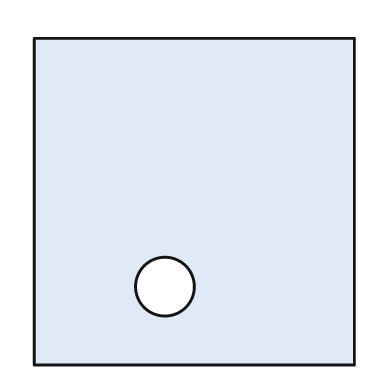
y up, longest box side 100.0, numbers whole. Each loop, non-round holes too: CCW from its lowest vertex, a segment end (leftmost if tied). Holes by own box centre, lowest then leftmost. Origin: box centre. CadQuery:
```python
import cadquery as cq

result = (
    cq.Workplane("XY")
    .moveTo(-49.0, -50.0)
    .lineTo(49.0, -50.0)
    .lineTo(49.0, 50.0)
    .lineTo(-49.0, 50.0)
    .close()
    .moveTo(-9.0, -26.0)
    .circle(9.0)
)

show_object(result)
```